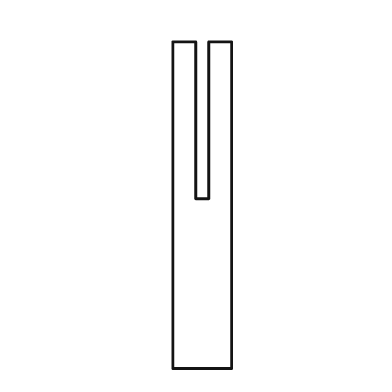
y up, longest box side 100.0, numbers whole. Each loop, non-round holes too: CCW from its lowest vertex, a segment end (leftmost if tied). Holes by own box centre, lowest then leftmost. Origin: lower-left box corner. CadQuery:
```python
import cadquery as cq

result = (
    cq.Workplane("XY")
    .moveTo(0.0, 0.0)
    .lineTo(18.0, 0.0)
    .lineTo(18.0, 100.0)
    .lineTo(11.0, 100.0)
    .lineTo(11.0, 52.0)
    .lineTo(7.0, 52.0)
    .lineTo(7.0, 100.0)
    .lineTo(0.0, 100.0)
    .close()
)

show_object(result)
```